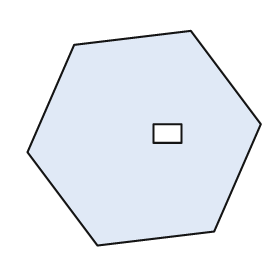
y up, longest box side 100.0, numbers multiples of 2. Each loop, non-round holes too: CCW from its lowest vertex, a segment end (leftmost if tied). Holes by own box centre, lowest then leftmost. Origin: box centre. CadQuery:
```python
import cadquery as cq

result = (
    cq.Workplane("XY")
    .moveTo(-20.0, -46.0)
    .lineTo(30.0, -40.0)
    .lineTo(50.0, 6.0)
    .lineTo(20.0, 46.0)
    .lineTo(-30.0, 40.0)
    .lineTo(-50.0, -6.0)
    .close()
    .moveTo(4.0, -2.0)
    .lineTo(16.0, -2.0)
    .lineTo(16.0, 6.0)
    .lineTo(4.0, 6.0)
    .close()
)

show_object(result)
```